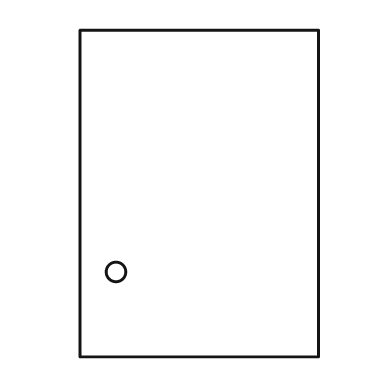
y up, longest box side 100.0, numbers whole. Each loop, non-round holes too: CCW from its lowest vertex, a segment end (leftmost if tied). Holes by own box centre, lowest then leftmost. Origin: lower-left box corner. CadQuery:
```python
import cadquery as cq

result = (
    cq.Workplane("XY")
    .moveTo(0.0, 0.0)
    .lineTo(73.0, 0.0)
    .lineTo(73.0, 100.0)
    .lineTo(0.0, 100.0)
    .close()
    .moveTo(11.0, 26.0)
    .circle(3.0)
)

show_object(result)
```